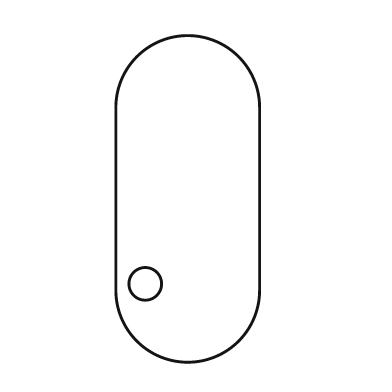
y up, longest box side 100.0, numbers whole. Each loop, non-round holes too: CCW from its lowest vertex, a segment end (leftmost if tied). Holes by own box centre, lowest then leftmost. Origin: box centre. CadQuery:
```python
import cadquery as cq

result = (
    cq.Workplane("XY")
    .moveTo(-22.0, -28.0)
    .threePointArc((0.0, -50.0), (22.0, -28.0))
    .lineTo(22.0, 28.0)
    .threePointArc((0.0, 50.0), (-22.0, 28.0))
    .close()
    .moveTo(-13.0, -26.0)
    .circle(5.0)
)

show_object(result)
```